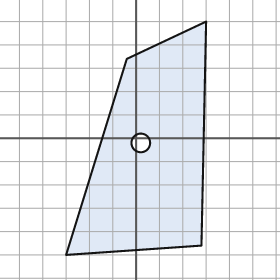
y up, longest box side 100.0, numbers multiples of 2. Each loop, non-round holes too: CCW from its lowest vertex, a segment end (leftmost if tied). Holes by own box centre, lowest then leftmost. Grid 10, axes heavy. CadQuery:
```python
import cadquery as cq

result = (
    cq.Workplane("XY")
    .moveTo(-30.0, -50.0)
    .lineTo(28.0, -46.0)
    .lineTo(30.0, 50.0)
    .lineTo(-4.0, 34.0)
    .close()
    .moveTo(2.0, -2.0)
    .circle(4.0)
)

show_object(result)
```